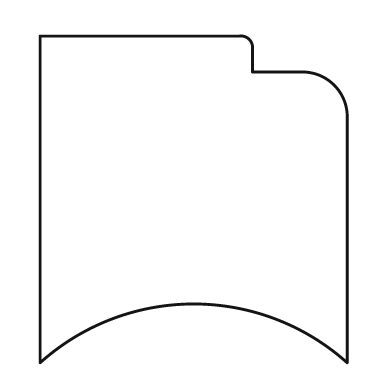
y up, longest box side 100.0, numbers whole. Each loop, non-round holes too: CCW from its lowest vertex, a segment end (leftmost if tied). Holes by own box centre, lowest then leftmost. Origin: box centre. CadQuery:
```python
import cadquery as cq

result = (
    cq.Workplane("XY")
    .moveTo(-47.0, -50.0)
    .threePointArc((0.0, -32.0), (47.0, -50.0))
    .lineTo(47.0, 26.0)
    .threePointArc((43.0, 35.0), (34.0, 39.0))
    .lineTo(18.0, 39.0)
    .lineTo(18.0, 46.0)
    .threePointArc((17.0, 49.0), (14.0, 50.0))
    .lineTo(-47.0, 50.0)
    .close()
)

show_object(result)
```